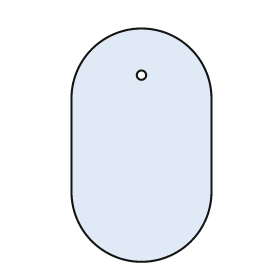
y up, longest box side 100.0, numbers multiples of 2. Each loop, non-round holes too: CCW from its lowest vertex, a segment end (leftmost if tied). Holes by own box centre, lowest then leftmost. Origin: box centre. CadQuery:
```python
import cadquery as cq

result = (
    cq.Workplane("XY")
    .moveTo(-30.0, -20.0)
    .threePointArc((0.0, -50.0), (30.0, -20.0))
    .lineTo(30.0, 20.0)
    .threePointArc((0.0, 50.0), (-30.0, 20.0))
    .close()
    .moveTo(0.0, 30.0)
    .circle(2.0)
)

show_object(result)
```